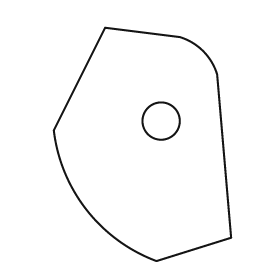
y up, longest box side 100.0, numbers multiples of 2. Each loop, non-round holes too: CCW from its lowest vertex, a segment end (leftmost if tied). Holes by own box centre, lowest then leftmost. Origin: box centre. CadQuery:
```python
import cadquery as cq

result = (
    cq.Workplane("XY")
    .moveTo(6.0, -50.0)
    .lineTo(38.0, -40.0)
    .lineTo(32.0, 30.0)
    .threePointArc((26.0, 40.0), (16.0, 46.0))
    .lineTo(-16.0, 50.0)
    .lineTo(-38.0, 6.0)
    .threePointArc((-24.0, -28.0), (6.0, -50.0))
    .close()
    .moveTo(8.0, 10.0)
    .circle(8.0)
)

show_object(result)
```